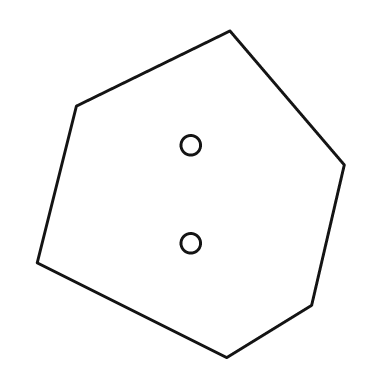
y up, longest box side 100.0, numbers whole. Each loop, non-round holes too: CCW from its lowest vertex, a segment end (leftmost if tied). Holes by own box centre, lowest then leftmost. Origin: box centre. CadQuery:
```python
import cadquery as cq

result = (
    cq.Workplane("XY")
    .moveTo(11.0, -50.0)
    .lineTo(37.0, -34.0)
    .lineTo(47.0, 9.0)
    .lineTo(12.0, 50.0)
    .lineTo(-35.0, 27.0)
    .lineTo(-47.0, -21.0)
    .close()
    .moveTo(0.0, -15.0)
    .circle(3.0)
    .moveTo(0.0, 15.0)
    .circle(3.0)
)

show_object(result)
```